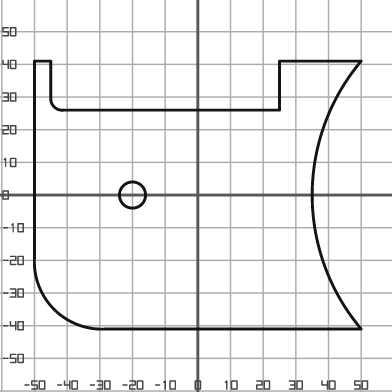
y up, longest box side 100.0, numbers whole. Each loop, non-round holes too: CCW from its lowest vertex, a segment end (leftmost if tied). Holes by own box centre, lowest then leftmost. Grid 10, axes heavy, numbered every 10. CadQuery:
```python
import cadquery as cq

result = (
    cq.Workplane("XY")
    .moveTo(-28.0, -41.0)
    .lineTo(50.0, -41.0)
    .threePointArc((35.0, 0.0), (50.0, 41.0))
    .lineTo(25.0, 41.0)
    .lineTo(25.0, 26.0)
    .lineTo(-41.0, 26.0)
    .threePointArc((-44.0, 27.0), (-45.0, 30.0))
    .lineTo(-45.0, 41.0)
    .lineTo(-50.0, 41.0)
    .lineTo(-50.0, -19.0)
    .threePointArc((-44.0, -35.0), (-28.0, -41.0))
    .close()
    .moveTo(-20.0, 0.0)
    .circle(4.0)
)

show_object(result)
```